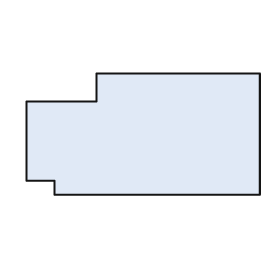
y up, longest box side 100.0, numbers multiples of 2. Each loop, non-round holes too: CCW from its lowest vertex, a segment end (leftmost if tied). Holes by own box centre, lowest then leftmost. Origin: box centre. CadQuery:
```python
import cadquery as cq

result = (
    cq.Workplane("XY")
    .moveTo(-38.0, -26.0)
    .lineTo(50.0, -26.0)
    .lineTo(50.0, 26.0)
    .lineTo(-20.0, 26.0)
    .lineTo(-20.0, 14.0)
    .lineTo(-50.0, 14.0)
    .lineTo(-50.0, -20.0)
    .lineTo(-38.0, -20.0)
    .close()
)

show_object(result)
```